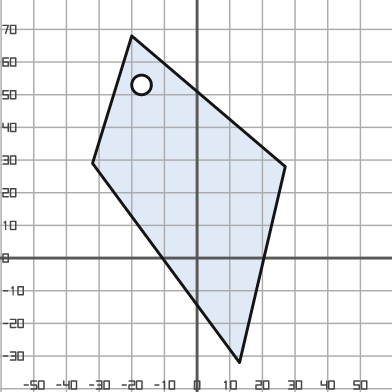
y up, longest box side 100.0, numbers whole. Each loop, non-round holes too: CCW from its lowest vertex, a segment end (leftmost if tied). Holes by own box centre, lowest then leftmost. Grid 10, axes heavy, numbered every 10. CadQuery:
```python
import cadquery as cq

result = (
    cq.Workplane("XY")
    .moveTo(13.0, -32.0)
    .lineTo(27.0, 28.0)
    .lineTo(-20.0, 68.0)
    .lineTo(-32.0, 29.0)
    .close()
    .moveTo(-17.0, 53.0)
    .circle(3.0)
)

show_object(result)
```